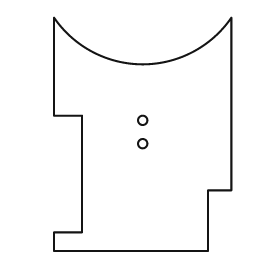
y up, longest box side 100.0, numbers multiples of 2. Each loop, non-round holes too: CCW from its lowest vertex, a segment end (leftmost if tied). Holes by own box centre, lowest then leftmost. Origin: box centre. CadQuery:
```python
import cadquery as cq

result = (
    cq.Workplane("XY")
    .moveTo(-38.0, -50.0)
    .lineTo(28.0, -50.0)
    .lineTo(28.0, -24.0)
    .lineTo(38.0, -24.0)
    .lineTo(38.0, 50.0)
    .threePointArc((0.0, 30.0), (-38.0, 50.0))
    .lineTo(-38.0, 8.0)
    .lineTo(-26.0, 8.0)
    .lineTo(-26.0, -42.0)
    .lineTo(-38.0, -42.0)
    .close()
    .moveTo(0.0, -4.0)
    .circle(2.0)
    .moveTo(0.0, 6.0)
    .circle(2.0)
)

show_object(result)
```